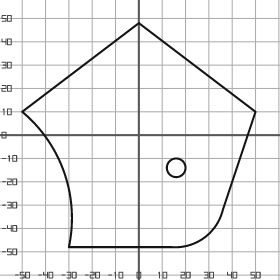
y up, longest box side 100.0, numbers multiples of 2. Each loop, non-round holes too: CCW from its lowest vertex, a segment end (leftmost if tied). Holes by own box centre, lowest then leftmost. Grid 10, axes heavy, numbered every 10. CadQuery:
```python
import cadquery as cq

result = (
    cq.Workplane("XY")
    .moveTo(-30.0, -48.0)
    .lineTo(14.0, -48.0)
    .threePointArc((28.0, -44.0), (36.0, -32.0))
    .lineTo(50.0, 10.0)
    .lineTo(0.0, 48.0)
    .lineTo(-50.0, 10.0)
    .threePointArc((-32.0, -16.0), (-30.0, -48.0))
    .close()
    .moveTo(16.0, -14.0)
    .circle(4.0)
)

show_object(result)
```